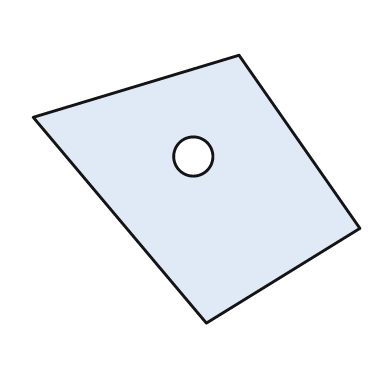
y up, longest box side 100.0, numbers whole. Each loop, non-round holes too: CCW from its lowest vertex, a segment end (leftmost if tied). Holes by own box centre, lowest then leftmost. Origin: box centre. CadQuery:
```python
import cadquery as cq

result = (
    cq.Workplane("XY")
    .moveTo(3.0, -41.0)
    .lineTo(50.0, -12.0)
    .lineTo(13.0, 41.0)
    .lineTo(-50.0, 22.0)
    .close()
    .moveTo(-1.0, 10.0)
    .circle(6.0)
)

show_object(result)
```